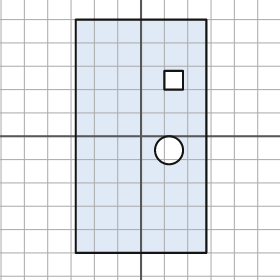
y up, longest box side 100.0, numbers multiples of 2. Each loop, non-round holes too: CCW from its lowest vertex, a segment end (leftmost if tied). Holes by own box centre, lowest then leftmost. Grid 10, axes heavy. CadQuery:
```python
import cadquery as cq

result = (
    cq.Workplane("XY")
    .moveTo(-28.0, -50.0)
    .lineTo(28.0, -50.0)
    .lineTo(28.0, 50.0)
    .lineTo(-28.0, 50.0)
    .close()
    .moveTo(12.0, -6.0)
    .circle(6.0)
    .moveTo(10.0, 20.0)
    .lineTo(18.0, 20.0)
    .lineTo(18.0, 28.0)
    .lineTo(10.0, 28.0)
    .close()
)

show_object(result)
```